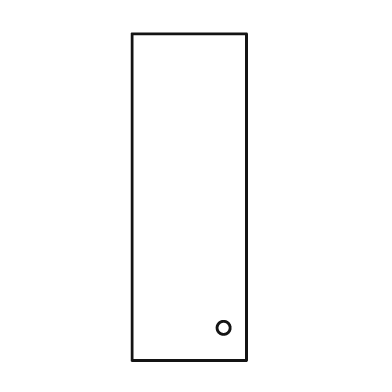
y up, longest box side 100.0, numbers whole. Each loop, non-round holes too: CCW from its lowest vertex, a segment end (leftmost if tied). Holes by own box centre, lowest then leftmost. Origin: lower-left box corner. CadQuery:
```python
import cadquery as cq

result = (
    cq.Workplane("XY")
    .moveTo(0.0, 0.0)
    .lineTo(35.0, 0.0)
    .lineTo(35.0, 100.0)
    .lineTo(0.0, 100.0)
    .close()
    .moveTo(28.0, 10.0)
    .circle(2.0)
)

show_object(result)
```